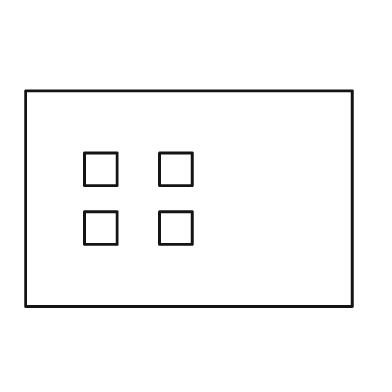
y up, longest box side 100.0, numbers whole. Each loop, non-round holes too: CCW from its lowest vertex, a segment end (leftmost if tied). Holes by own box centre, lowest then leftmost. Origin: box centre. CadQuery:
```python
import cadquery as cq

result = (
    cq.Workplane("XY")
    .moveTo(-50.0, -33.0)
    .lineTo(50.0, -33.0)
    .lineTo(50.0, 33.0)
    .lineTo(-50.0, 33.0)
    .close()
    .moveTo(-32.0, -14.0)
    .lineTo(-22.0, -14.0)
    .lineTo(-22.0, -4.0)
    .lineTo(-32.0, -4.0)
    .close()
    .moveTo(-9.0, -14.0)
    .lineTo(1.0, -14.0)
    .lineTo(1.0, -4.0)
    .lineTo(-9.0, -4.0)
    .close()
    .moveTo(-32.0, 4.0)
    .lineTo(-22.0, 4.0)
    .lineTo(-22.0, 14.0)
    .lineTo(-32.0, 14.0)
    .close()
    .moveTo(-9.0, 4.0)
    .lineTo(1.0, 4.0)
    .lineTo(1.0, 14.0)
    .lineTo(-9.0, 14.0)
    .close()
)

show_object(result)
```